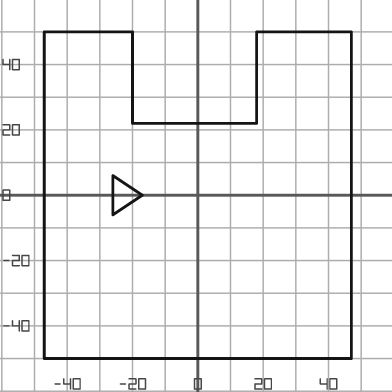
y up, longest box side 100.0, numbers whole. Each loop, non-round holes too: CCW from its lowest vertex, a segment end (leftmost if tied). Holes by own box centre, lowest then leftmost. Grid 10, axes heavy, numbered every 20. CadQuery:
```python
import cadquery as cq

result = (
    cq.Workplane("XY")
    .moveTo(-47.0, -50.0)
    .lineTo(47.0, -50.0)
    .lineTo(47.0, 50.0)
    .lineTo(18.0, 50.0)
    .lineTo(18.0, 22.0)
    .lineTo(-20.0, 22.0)
    .lineTo(-20.0, 50.0)
    .lineTo(-47.0, 50.0)
    .close()
    .moveTo(-26.0, -6.0)
    .lineTo(-17.0, 0.0)
    .lineTo(-26.0, 6.0)
    .close()
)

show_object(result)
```